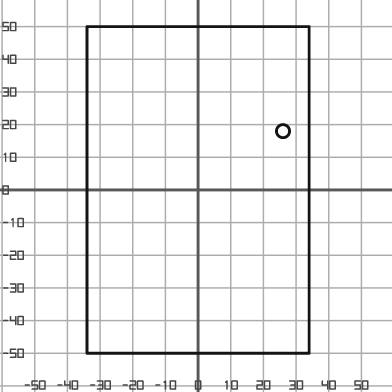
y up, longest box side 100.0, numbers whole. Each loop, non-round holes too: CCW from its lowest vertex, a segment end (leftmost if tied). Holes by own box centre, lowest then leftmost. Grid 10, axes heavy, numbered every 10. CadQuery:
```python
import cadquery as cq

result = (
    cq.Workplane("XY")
    .moveTo(-34.0, -50.0)
    .lineTo(34.0, -50.0)
    .lineTo(34.0, 50.0)
    .lineTo(-34.0, 50.0)
    .close()
    .moveTo(26.0, 18.0)
    .circle(2.0)
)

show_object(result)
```